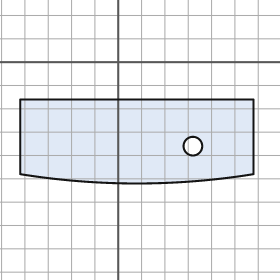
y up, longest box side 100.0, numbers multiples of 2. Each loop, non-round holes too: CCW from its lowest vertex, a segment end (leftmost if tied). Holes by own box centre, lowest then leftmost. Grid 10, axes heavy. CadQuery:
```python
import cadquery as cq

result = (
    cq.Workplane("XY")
    .moveTo(-42.0, -48.0)
    .threePointArc((8.0, -52.0), (58.0, -48.0))
    .lineTo(58.0, -16.0)
    .lineTo(-42.0, -16.0)
    .close()
    .moveTo(32.0, -36.0)
    .circle(4.0)
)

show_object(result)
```